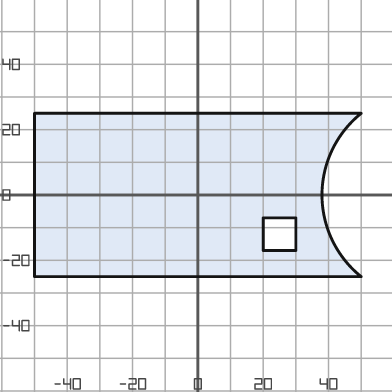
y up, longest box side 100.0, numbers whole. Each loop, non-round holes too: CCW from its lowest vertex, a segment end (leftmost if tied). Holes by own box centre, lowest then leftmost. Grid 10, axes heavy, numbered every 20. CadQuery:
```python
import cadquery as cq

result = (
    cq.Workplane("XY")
    .moveTo(-50.0, -25.0)
    .lineTo(50.0, -25.0)
    .threePointArc((38.0, 0.0), (50.0, 25.0))
    .lineTo(-50.0, 25.0)
    .close()
    .moveTo(20.0, -17.0)
    .lineTo(30.0, -17.0)
    .lineTo(30.0, -7.0)
    .lineTo(20.0, -7.0)
    .close()
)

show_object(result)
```